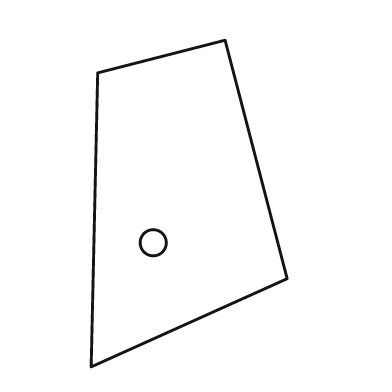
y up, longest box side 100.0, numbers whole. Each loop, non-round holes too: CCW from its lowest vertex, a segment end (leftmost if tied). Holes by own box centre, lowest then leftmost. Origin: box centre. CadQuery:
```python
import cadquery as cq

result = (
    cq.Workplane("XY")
    .moveTo(-30.0, -50.0)
    .lineTo(30.0, -23.0)
    .lineTo(11.0, 50.0)
    .lineTo(-28.0, 40.0)
    .close()
    .moveTo(-11.0, -12.0)
    .circle(4.0)
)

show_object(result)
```